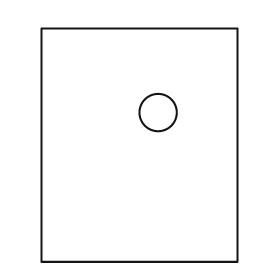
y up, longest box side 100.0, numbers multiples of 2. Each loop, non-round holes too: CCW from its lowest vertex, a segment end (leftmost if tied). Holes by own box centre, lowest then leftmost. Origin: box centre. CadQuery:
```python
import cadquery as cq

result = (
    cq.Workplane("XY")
    .moveTo(-42.0, -50.0)
    .lineTo(42.0, -50.0)
    .lineTo(42.0, 50.0)
    .lineTo(-42.0, 50.0)
    .close()
    .moveTo(8.0, 14.0)
    .circle(8.0)
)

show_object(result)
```